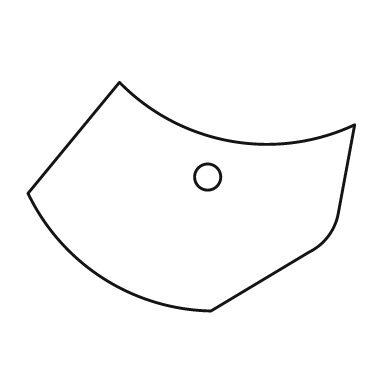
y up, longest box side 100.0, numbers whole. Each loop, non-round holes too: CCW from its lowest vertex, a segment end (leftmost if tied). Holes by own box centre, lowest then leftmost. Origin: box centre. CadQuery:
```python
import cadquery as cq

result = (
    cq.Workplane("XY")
    .moveTo(6.0, -35.0)
    .lineTo(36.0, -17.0)
    .threePointArc((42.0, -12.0), (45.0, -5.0))
    .lineTo(50.0, 22.0)
    .threePointArc((12.0, 17.0), (-22.0, 35.0))
    .lineTo(-50.0, 1.0)
    .threePointArc((-27.0, -25.0), (6.0, -35.0))
    .close()
    .moveTo(5.0, 6.0)
    .circle(4.0)
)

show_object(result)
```